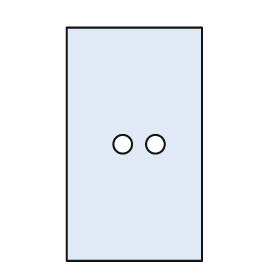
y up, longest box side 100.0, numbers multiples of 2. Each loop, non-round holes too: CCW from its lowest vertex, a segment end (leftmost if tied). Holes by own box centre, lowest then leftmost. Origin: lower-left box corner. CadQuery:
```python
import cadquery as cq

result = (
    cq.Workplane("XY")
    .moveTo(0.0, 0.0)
    .lineTo(58.0, 0.0)
    .lineTo(58.0, 100.0)
    .lineTo(0.0, 100.0)
    .close()
    .moveTo(24.0, 50.0)
    .circle(4.0)
    .moveTo(38.0, 50.0)
    .circle(4.0)
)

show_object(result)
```